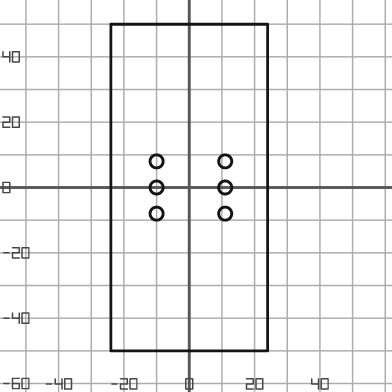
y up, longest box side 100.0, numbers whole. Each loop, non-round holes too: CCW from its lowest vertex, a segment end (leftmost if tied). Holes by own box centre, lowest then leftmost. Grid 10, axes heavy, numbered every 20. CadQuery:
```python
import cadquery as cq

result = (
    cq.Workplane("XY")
    .moveTo(-24.0, -50.0)
    .lineTo(24.0, -50.0)
    .lineTo(24.0, 50.0)
    .lineTo(-24.0, 50.0)
    .close()
    .moveTo(-10.0, -8.0)
    .circle(2.0)
    .moveTo(11.0, -8.0)
    .circle(2.0)
    .moveTo(-10.0, 0.0)
    .circle(2.0)
    .moveTo(11.0, 0.0)
    .circle(2.0)
    .moveTo(-10.0, 8.0)
    .circle(2.0)
    .moveTo(11.0, 8.0)
    .circle(2.0)
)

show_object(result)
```